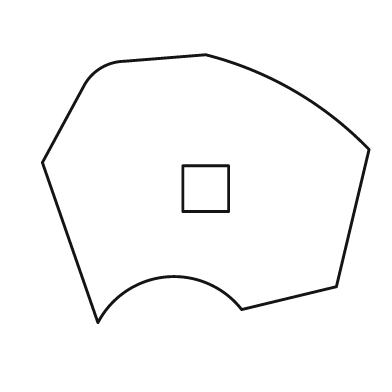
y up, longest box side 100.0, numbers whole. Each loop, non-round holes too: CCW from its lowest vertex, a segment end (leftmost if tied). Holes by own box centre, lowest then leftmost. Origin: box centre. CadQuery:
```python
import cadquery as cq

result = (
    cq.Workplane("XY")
    .moveTo(-33.0, -41.0)
    .threePointArc((-12.0, -27.0), (11.0, -37.0))
    .lineTo(40.0, -30.0)
    .lineTo(50.0, 12.0)
    .threePointArc((27.0, 30.0), (0.0, 41.0))
    .lineTo(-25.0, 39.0)
    .threePointArc((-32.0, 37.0), (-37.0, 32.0))
    .lineTo(-50.0, 8.0)
    .close()
    .moveTo(-7.0, -7.0)
    .lineTo(7.0, -7.0)
    .lineTo(7.0, 7.0)
    .lineTo(-7.0, 7.0)
    .close()
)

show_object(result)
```